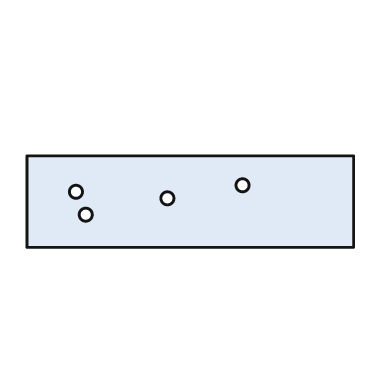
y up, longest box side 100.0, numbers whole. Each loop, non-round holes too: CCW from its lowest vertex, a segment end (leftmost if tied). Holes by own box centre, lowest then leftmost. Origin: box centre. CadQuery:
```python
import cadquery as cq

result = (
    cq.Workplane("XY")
    .moveTo(-50.0, -14.0)
    .lineTo(50.0, -14.0)
    .lineTo(50.0, 14.0)
    .lineTo(-50.0, 14.0)
    .close()
    .moveTo(-32.0, -4.0)
    .circle(2.0)
    .moveTo(-7.0, 1.0)
    .circle(2.0)
    .moveTo(-35.0, 3.0)
    .circle(2.0)
    .moveTo(16.0, 5.0)
    .circle(2.0)
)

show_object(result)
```